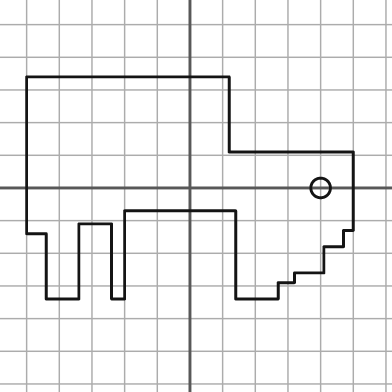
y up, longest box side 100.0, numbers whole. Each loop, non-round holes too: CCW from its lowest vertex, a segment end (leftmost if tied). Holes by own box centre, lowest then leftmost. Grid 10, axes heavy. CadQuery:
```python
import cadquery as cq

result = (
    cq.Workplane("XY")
    .moveTo(-44.0, -34.0)
    .lineTo(-34.0, -34.0)
    .lineTo(-34.0, -11.0)
    .lineTo(-24.0, -11.0)
    .lineTo(-24.0, -34.0)
    .lineTo(-20.0, -34.0)
    .lineTo(-20.0, -7.0)
    .lineTo(14.0, -7.0)
    .lineTo(14.0, -34.0)
    .lineTo(27.0, -34.0)
    .lineTo(27.0, -29.0)
    .lineTo(32.0, -29.0)
    .lineTo(32.0, -26.0)
    .lineTo(41.0, -26.0)
    .lineTo(41.0, -18.0)
    .lineTo(47.0, -18.0)
    .lineTo(47.0, -13.0)
    .lineTo(50.0, -13.0)
    .lineTo(50.0, 11.0)
    .lineTo(12.0, 11.0)
    .lineTo(12.0, 34.0)
    .lineTo(-50.0, 34.0)
    .lineTo(-50.0, -14.0)
    .lineTo(-44.0, -14.0)
    .close()
    .moveTo(40.0, 0.0)
    .circle(3.0)
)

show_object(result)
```